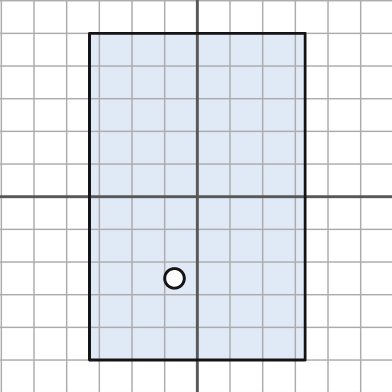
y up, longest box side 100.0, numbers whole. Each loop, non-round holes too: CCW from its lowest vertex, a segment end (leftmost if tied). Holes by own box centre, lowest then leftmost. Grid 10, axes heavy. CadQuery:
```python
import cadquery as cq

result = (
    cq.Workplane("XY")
    .moveTo(-33.0, -50.0)
    .lineTo(33.0, -50.0)
    .lineTo(33.0, 50.0)
    .lineTo(-33.0, 50.0)
    .close()
    .moveTo(-7.0, -25.0)
    .circle(3.0)
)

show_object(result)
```